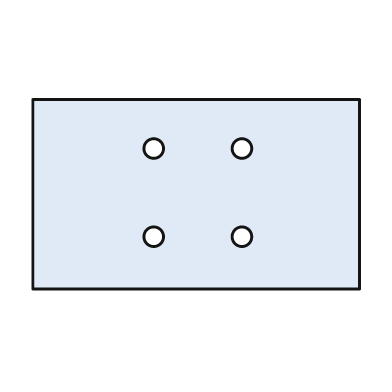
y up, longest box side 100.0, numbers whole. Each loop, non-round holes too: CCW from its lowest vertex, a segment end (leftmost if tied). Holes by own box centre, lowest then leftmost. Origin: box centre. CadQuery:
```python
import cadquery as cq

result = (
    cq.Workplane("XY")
    .moveTo(-50.0, -29.0)
    .lineTo(50.0, -29.0)
    .lineTo(50.0, 29.0)
    .lineTo(-50.0, 29.0)
    .close()
    .moveTo(-13.0, -13.0)
    .circle(3.0)
    .moveTo(14.0, -13.0)
    .circle(3.0)
    .moveTo(-13.0, 14.0)
    .circle(3.0)
    .moveTo(14.0, 14.0)
    .circle(3.0)
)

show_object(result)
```